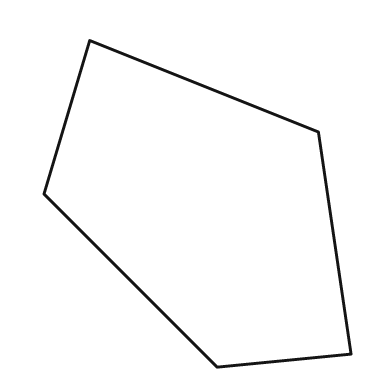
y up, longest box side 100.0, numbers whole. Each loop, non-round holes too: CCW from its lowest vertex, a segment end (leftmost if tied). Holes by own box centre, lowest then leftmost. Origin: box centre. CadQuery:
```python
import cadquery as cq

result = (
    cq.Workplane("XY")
    .moveTo(6.0, -50.0)
    .lineTo(47.0, -46.0)
    .lineTo(37.0, 22.0)
    .lineTo(-33.0, 50.0)
    .lineTo(-47.0, 3.0)
    .close()
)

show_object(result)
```